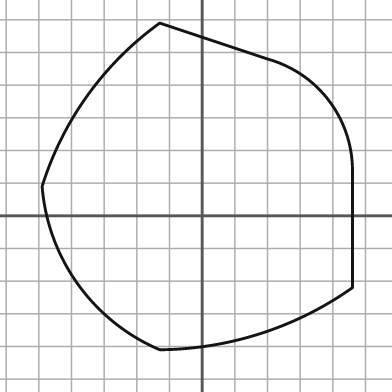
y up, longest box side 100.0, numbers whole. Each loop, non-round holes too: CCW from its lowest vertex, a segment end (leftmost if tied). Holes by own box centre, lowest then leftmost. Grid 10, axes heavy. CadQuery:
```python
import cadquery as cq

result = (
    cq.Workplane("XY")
    .moveTo(-13.0, -41.0)
    .threePointArc((18.0, -36.0), (46.0, -22.0))
    .lineTo(46.0, 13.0)
    .threePointArc((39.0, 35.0), (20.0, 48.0))
    .lineTo(-13.0, 59.0)
    .threePointArc((-35.0, 37.0), (-49.0, 9.0))
    .threePointArc((-38.0, -21.0), (-13.0, -41.0))
    .close()
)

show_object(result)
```